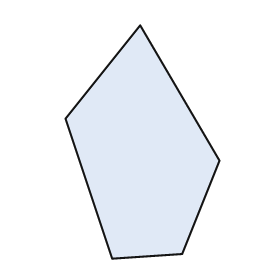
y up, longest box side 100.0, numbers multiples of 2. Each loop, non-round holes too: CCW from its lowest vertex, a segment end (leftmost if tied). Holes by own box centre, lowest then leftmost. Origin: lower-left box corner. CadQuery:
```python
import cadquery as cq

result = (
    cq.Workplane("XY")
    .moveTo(20.0, 0.0)
    .lineTo(50.0, 2.0)
    .lineTo(66.0, 42.0)
    .lineTo(32.0, 100.0)
    .lineTo(0.0, 60.0)
    .close()
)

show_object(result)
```